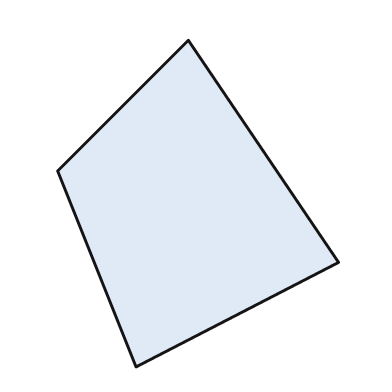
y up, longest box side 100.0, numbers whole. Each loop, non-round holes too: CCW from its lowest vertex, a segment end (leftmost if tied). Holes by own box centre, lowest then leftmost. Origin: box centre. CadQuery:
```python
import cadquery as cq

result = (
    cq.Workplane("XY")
    .moveTo(-19.0, -50.0)
    .lineTo(43.0, -18.0)
    .lineTo(-3.0, 50.0)
    .lineTo(-43.0, 10.0)
    .close()
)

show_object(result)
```